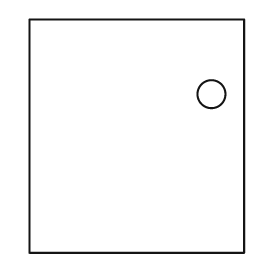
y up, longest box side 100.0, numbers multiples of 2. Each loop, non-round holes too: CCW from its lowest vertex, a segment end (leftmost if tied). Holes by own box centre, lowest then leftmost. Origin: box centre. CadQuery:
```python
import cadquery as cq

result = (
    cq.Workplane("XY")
    .moveTo(-46.0, -50.0)
    .lineTo(46.0, -50.0)
    .lineTo(46.0, 50.0)
    .lineTo(-46.0, 50.0)
    .close()
    .moveTo(32.0, 18.0)
    .circle(6.0)
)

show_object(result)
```